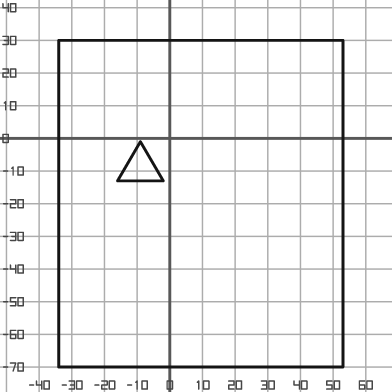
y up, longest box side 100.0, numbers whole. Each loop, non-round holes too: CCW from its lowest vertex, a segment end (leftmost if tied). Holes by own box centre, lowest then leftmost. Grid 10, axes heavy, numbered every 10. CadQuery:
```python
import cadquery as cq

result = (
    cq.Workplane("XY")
    .moveTo(-34.0, -70.0)
    .lineTo(53.0, -70.0)
    .lineTo(53.0, 30.0)
    .lineTo(-34.0, 30.0)
    .close()
    .moveTo(-16.0, -13.0)
    .lineTo(-2.0, -13.0)
    .lineTo(-9.0, -1.0)
    .close()
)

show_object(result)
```